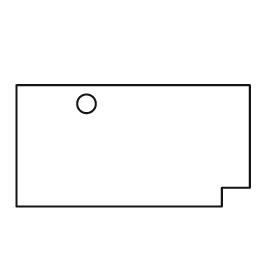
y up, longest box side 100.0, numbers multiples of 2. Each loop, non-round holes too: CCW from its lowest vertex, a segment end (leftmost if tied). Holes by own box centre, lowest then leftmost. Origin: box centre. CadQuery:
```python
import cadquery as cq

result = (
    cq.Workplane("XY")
    .moveTo(-50.0, -26.0)
    .lineTo(38.0, -26.0)
    .lineTo(38.0, -18.0)
    .lineTo(50.0, -18.0)
    .lineTo(50.0, 26.0)
    .lineTo(-50.0, 26.0)
    .close()
    .moveTo(-20.0, 18.0)
    .circle(4.0)
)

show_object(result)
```